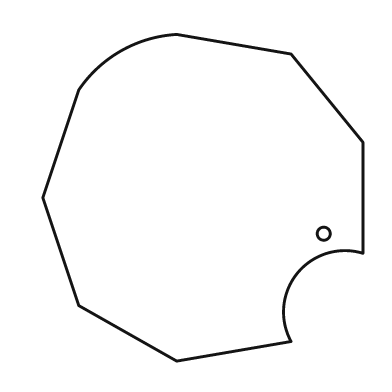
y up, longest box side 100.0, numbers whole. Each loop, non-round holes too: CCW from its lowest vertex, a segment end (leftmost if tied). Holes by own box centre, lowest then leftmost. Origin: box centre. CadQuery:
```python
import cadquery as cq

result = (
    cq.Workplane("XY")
    .moveTo(-8.0, -50.0)
    .lineTo(27.0, -44.0)
    .threePointArc((29.0, -23.0), (49.0, -17.0))
    .lineTo(49.0, 17.0)
    .lineTo(27.0, 44.0)
    .lineTo(-8.0, 50.0)
    .threePointArc((-25.0, 45.0), (-38.0, 33.0))
    .lineTo(-49.0, 0.0)
    .lineTo(-38.0, -33.0)
    .close()
    .moveTo(37.0, -11.0)
    .circle(2.0)
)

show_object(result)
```